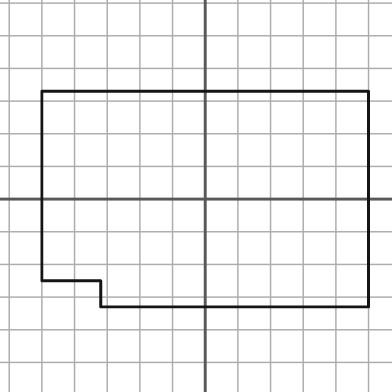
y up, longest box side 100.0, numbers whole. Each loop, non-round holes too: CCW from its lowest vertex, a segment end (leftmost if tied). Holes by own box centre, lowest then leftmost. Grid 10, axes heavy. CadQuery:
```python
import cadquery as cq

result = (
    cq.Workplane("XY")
    .moveTo(-32.0, -33.0)
    .lineTo(50.0, -33.0)
    .lineTo(50.0, 33.0)
    .lineTo(-50.0, 33.0)
    .lineTo(-50.0, -25.0)
    .lineTo(-32.0, -25.0)
    .close()
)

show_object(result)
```